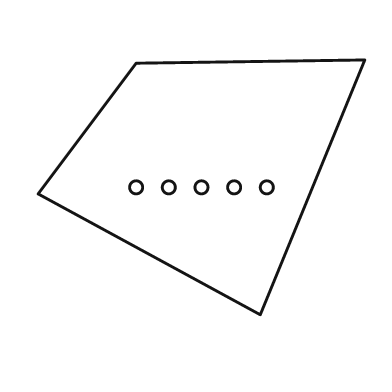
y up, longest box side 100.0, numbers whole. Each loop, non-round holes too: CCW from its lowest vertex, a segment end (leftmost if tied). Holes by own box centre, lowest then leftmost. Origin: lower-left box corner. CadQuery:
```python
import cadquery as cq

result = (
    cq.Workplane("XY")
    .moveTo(68.0, 0.0)
    .lineTo(100.0, 78.0)
    .lineTo(30.0, 77.0)
    .lineTo(0.0, 37.0)
    .close()
    .moveTo(30.0, 39.0)
    .circle(2.0)
    .moveTo(40.0, 39.0)
    .circle(2.0)
    .moveTo(50.0, 39.0)
    .circle(2.0)
    .moveTo(60.0, 39.0)
    .circle(2.0)
    .moveTo(70.0, 39.0)
    .circle(2.0)
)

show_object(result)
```